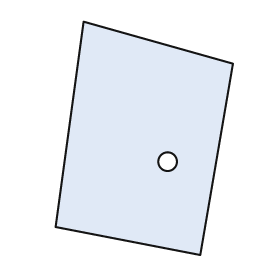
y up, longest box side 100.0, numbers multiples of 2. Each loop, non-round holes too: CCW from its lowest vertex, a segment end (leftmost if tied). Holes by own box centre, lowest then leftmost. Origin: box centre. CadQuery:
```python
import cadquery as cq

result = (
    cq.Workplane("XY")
    .moveTo(24.0, -50.0)
    .lineTo(38.0, 32.0)
    .lineTo(-26.0, 50.0)
    .lineTo(-38.0, -38.0)
    .close()
    .moveTo(10.0, -10.0)
    .circle(4.0)
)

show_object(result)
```